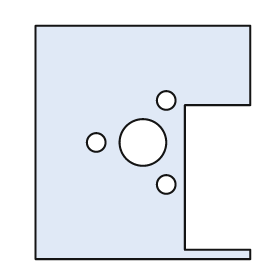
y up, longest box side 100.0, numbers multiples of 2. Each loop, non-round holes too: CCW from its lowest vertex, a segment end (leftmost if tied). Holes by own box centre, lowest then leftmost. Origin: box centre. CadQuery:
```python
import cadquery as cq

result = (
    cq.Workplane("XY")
    .moveTo(-46.0, -50.0)
    .lineTo(46.0, -50.0)
    .lineTo(46.0, -46.0)
    .lineTo(18.0, -46.0)
    .lineTo(18.0, 16.0)
    .lineTo(46.0, 16.0)
    .lineTo(46.0, 50.0)
    .lineTo(-46.0, 50.0)
    .close()
    .moveTo(10.0, -18.0)
    .circle(4.0)
    .moveTo(-20.0, 0.0)
    .circle(4.0)
    .moveTo(0.0, 0.0)
    .circle(10.0)
    .moveTo(10.0, 18.0)
    .circle(4.0)
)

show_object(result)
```